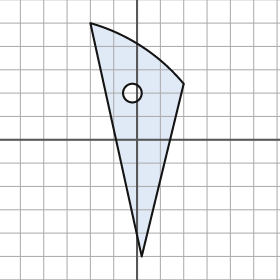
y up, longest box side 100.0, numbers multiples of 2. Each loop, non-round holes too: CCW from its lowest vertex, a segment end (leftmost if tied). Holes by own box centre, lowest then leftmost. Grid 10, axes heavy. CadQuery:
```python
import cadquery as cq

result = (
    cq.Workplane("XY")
    .moveTo(2.0, -50.0)
    .lineTo(20.0, 24.0)
    .threePointArc((2.0, 40.0), (-20.0, 50.0))
    .close()
    .moveTo(-2.0, 20.0)
    .circle(4.0)
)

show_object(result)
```